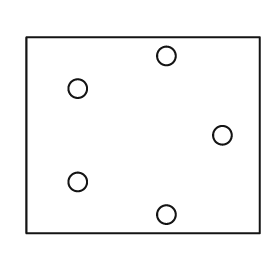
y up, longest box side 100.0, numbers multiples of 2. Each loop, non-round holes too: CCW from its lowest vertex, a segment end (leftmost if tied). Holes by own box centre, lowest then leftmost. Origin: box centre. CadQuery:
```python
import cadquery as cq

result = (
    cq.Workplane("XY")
    .moveTo(-50.0, -42.0)
    .lineTo(50.0, -42.0)
    .lineTo(50.0, 42.0)
    .lineTo(-50.0, 42.0)
    .close()
    .moveTo(10.0, -34.0)
    .circle(4.0)
    .moveTo(-28.0, -20.0)
    .circle(4.0)
    .moveTo(34.0, 0.0)
    .circle(4.0)
    .moveTo(-28.0, 20.0)
    .circle(4.0)
    .moveTo(10.0, 34.0)
    .circle(4.0)
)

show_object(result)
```